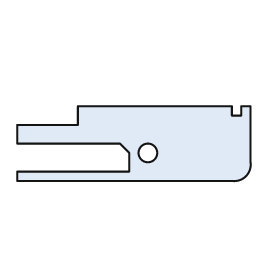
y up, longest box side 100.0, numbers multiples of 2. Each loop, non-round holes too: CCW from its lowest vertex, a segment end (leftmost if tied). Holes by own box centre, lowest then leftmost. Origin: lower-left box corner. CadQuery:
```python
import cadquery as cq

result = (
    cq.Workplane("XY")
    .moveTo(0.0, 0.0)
    .lineTo(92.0, 0.0)
    .threePointArc((98.0, 2.0), (100.0, 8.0))
    .lineTo(100.0, 32.0)
    .lineTo(96.0, 32.0)
    .lineTo(96.0, 28.0)
    .lineTo(92.0, 28.0)
    .lineTo(92.0, 32.0)
    .lineTo(26.0, 32.0)
    .lineTo(26.0, 24.0)
    .lineTo(0.0, 24.0)
    .lineTo(0.0, 16.0)
    .lineTo(44.0, 16.0)
    .lineTo(48.0, 12.0)
    .lineTo(48.0, 4.0)
    .lineTo(0.0, 4.0)
    .close()
    .moveTo(56.0, 12.0)
    .circle(4.0)
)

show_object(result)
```